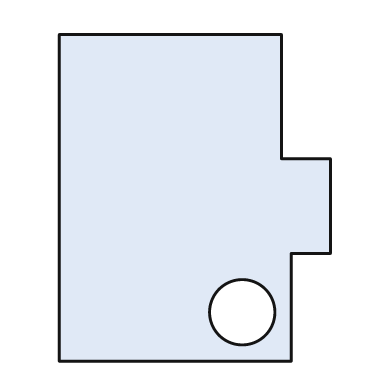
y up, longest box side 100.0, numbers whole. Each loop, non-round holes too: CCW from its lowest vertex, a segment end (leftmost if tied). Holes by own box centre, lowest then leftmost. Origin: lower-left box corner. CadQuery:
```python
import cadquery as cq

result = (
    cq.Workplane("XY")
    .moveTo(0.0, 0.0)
    .lineTo(71.0, 0.0)
    .lineTo(71.0, 33.0)
    .lineTo(83.0, 33.0)
    .lineTo(83.0, 62.0)
    .lineTo(68.0, 62.0)
    .lineTo(68.0, 100.0)
    .lineTo(0.0, 100.0)
    .close()
    .moveTo(56.0, 15.0)
    .circle(10.0)
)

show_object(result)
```